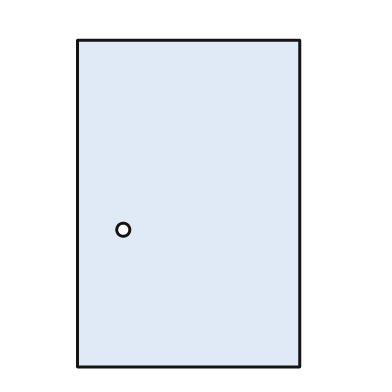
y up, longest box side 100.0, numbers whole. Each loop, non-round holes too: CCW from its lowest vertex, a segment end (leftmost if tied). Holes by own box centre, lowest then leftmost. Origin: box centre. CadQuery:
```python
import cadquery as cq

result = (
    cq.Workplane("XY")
    .moveTo(-34.0, -50.0)
    .lineTo(34.0, -50.0)
    .lineTo(34.0, 50.0)
    .lineTo(-34.0, 50.0)
    .close()
    .moveTo(-20.0, -8.0)
    .circle(2.0)
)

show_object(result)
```